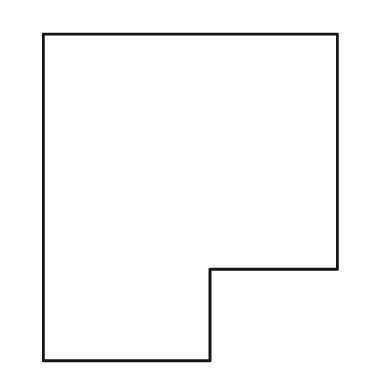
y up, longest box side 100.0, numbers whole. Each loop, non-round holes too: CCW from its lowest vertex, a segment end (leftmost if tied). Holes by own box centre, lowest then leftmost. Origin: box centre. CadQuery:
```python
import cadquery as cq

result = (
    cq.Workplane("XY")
    .moveTo(-45.0, -50.0)
    .lineTo(6.0, -50.0)
    .lineTo(6.0, -22.0)
    .lineTo(45.0, -22.0)
    .lineTo(45.0, 50.0)
    .lineTo(-45.0, 50.0)
    .close()
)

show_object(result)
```